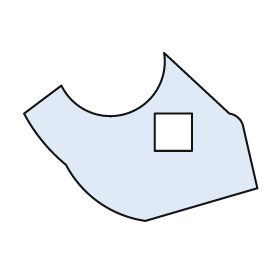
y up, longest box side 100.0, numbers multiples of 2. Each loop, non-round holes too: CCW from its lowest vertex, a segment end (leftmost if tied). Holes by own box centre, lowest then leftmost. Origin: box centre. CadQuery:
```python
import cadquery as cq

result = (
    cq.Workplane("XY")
    .moveTo(2.0, -36.0)
    .lineTo(50.0, -22.0)
    .lineTo(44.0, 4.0)
    .threePointArc((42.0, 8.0), (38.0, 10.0))
    .lineTo(10.0, 36.0)
    .threePointArc((-6.0, 10.0), (-34.0, 22.0))
    .lineTo(-50.0, 10.0)
    .threePointArc((-42.0, -2.0), (-32.0, -12.0))
    .threePointArc((-18.0, -28.0), (2.0, -36.0))
    .close()
    .moveTo(6.0, -6.0)
    .lineTo(22.0, -6.0)
    .lineTo(22.0, 10.0)
    .lineTo(6.0, 10.0)
    .close()
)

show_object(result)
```